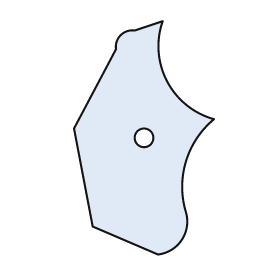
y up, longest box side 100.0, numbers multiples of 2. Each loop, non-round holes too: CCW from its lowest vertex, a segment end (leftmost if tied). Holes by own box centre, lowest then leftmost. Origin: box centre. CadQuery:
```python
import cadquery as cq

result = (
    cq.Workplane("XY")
    .moveTo(6.0, -50.0)
    .threePointArc((16.0, -44.0), (18.0, -32.0))
    .threePointArc((18.0, -10.0), (30.0, 8.0))
    .threePointArc((10.0, 24.0), (8.0, 50.0))
    .lineTo(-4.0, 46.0)
    .threePointArc((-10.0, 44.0), (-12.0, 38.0))
    .lineTo(-30.0, 4.0)
    .lineTo(-22.0, -38.0)
    .close()
    .moveTo(0.0, 0.0)
    .circle(4.0)
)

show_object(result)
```